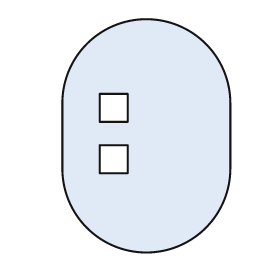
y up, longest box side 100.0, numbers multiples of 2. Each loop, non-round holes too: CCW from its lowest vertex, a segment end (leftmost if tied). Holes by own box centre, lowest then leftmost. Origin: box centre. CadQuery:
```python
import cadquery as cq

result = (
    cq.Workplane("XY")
    .moveTo(-36.0, -14.0)
    .threePointArc((0.0, -50.0), (36.0, -14.0))
    .lineTo(36.0, 14.0)
    .threePointArc((0.0, 50.0), (-36.0, 14.0))
    .close()
    .moveTo(-20.0, -16.0)
    .lineTo(-8.0, -16.0)
    .lineTo(-8.0, -4.0)
    .lineTo(-20.0, -4.0)
    .close()
    .moveTo(-20.0, 6.0)
    .lineTo(-8.0, 6.0)
    .lineTo(-8.0, 18.0)
    .lineTo(-20.0, 18.0)
    .close()
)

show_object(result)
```